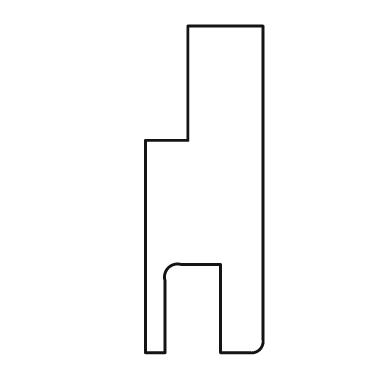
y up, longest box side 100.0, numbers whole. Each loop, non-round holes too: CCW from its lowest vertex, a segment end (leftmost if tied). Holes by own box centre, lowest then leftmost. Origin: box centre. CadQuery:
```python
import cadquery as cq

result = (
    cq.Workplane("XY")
    .moveTo(-18.0, -50.0)
    .lineTo(-12.0, -50.0)
    .lineTo(-12.0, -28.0)
    .threePointArc((-11.0, -24.0), (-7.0, -23.0))
    .lineTo(5.0, -23.0)
    .lineTo(5.0, -50.0)
    .lineTo(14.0, -50.0)
    .threePointArc((17.0, -49.0), (18.0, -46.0))
    .lineTo(18.0, 50.0)
    .lineTo(-5.0, 50.0)
    .lineTo(-5.0, 15.0)
    .lineTo(-18.0, 15.0)
    .close()
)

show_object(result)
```